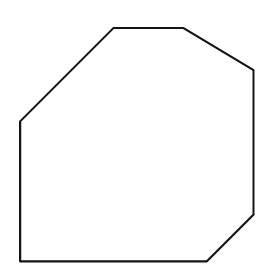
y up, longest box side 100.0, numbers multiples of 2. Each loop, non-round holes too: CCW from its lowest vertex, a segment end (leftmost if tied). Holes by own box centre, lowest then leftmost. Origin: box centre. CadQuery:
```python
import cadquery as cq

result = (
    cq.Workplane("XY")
    .moveTo(-50.0, -50.0)
    .lineTo(30.0, -50.0)
    .lineTo(50.0, -30.0)
    .lineTo(50.0, 32.0)
    .lineTo(20.0, 50.0)
    .lineTo(-10.0, 50.0)
    .lineTo(-50.0, 10.0)
    .close()
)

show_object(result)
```